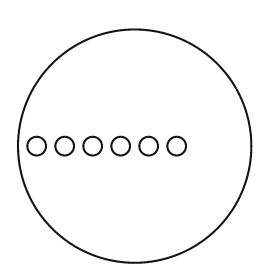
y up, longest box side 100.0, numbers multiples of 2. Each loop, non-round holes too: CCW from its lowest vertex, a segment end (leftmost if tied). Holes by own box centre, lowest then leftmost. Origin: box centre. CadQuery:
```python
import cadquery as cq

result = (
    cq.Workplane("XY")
    .moveTo(0.0, 0.0)
    .circle(50.0)
    .moveTo(-42.0, 0.0)
    .circle(4.0)
    .moveTo(-30.0, 0.0)
    .circle(4.0)
    .moveTo(-18.0, 0.0)
    .circle(4.0)
    .moveTo(-6.0, 0.0)
    .circle(4.0)
    .moveTo(6.0, 0.0)
    .circle(4.0)
    .moveTo(18.0, 0.0)
    .circle(4.0)
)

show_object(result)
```